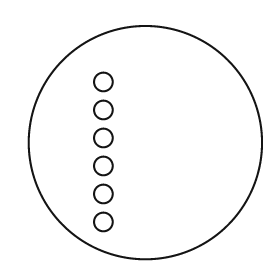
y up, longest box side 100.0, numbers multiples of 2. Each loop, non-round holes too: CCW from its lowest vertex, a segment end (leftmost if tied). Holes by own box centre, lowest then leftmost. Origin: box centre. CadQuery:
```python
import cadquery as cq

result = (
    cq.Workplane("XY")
    .moveTo(0.0, 0.0)
    .circle(50.0)
    .moveTo(-18.0, -34.0)
    .circle(4.0)
    .moveTo(-18.0, -22.0)
    .circle(4.0)
    .moveTo(-18.0, -10.0)
    .circle(4.0)
    .moveTo(-18.0, 2.0)
    .circle(4.0)
    .moveTo(-18.0, 14.0)
    .circle(4.0)
    .moveTo(-18.0, 26.0)
    .circle(4.0)
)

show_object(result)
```